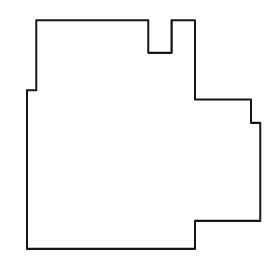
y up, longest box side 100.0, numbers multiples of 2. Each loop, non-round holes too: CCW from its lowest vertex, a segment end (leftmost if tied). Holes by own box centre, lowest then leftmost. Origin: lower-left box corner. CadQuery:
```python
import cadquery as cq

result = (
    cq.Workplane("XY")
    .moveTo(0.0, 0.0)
    .lineTo(72.0, 0.0)
    .lineTo(72.0, 12.0)
    .lineTo(100.0, 12.0)
    .lineTo(100.0, 54.0)
    .lineTo(96.0, 54.0)
    .lineTo(96.0, 64.0)
    .lineTo(72.0, 64.0)
    .lineTo(72.0, 98.0)
    .lineTo(62.0, 98.0)
    .lineTo(62.0, 84.0)
    .lineTo(52.0, 84.0)
    .lineTo(52.0, 98.0)
    .lineTo(4.0, 98.0)
    .lineTo(4.0, 68.0)
    .lineTo(0.0, 68.0)
    .close()
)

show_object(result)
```